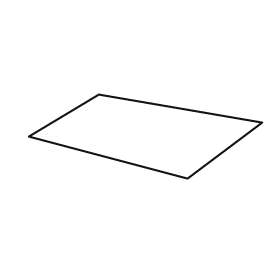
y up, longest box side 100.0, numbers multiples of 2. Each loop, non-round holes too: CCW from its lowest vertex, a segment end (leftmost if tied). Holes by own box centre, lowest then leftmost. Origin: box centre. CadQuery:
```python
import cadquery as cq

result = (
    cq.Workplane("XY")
    .moveTo(18.0, -18.0)
    .lineTo(50.0, 6.0)
    .lineTo(-20.0, 18.0)
    .lineTo(-50.0, 0.0)
    .close()
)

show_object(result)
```